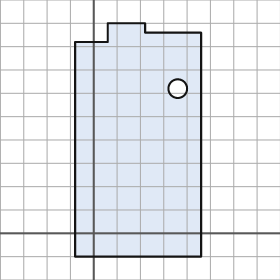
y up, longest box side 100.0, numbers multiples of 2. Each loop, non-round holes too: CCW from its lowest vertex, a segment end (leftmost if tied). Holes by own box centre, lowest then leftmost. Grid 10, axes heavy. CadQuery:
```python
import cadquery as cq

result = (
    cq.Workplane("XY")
    .moveTo(-8.0, -10.0)
    .lineTo(46.0, -10.0)
    .lineTo(46.0, 86.0)
    .lineTo(22.0, 86.0)
    .lineTo(22.0, 90.0)
    .lineTo(6.0, 90.0)
    .lineTo(6.0, 82.0)
    .lineTo(-8.0, 82.0)
    .close()
    .moveTo(36.0, 62.0)
    .circle(4.0)
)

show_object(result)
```